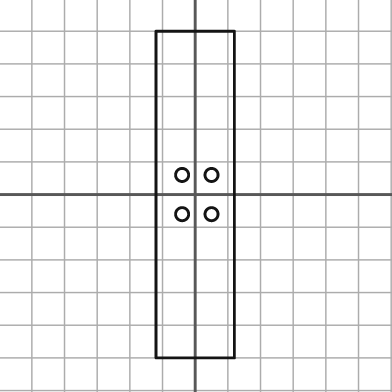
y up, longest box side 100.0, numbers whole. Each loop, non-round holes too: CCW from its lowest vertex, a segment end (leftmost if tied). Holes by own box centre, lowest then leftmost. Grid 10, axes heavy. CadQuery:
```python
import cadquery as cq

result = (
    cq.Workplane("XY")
    .moveTo(-12.0, -50.0)
    .lineTo(12.0, -50.0)
    .lineTo(12.0, 50.0)
    .lineTo(-12.0, 50.0)
    .close()
    .moveTo(-4.0, -6.0)
    .circle(2.0)
    .moveTo(5.0, -6.0)
    .circle(2.0)
    .moveTo(-4.0, 6.0)
    .circle(2.0)
    .moveTo(5.0, 6.0)
    .circle(2.0)
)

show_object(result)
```